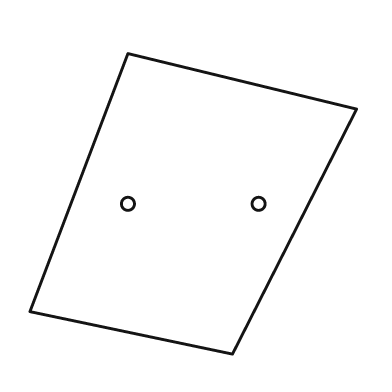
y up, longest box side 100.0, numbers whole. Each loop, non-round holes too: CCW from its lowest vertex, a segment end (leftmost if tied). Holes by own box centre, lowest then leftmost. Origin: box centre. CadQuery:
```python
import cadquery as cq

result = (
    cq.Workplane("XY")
    .moveTo(12.0, -46.0)
    .lineTo(50.0, 29.0)
    .lineTo(-20.0, 46.0)
    .lineTo(-50.0, -33.0)
    .close()
    .moveTo(-20.0, 0.0)
    .circle(2.0)
    .moveTo(20.0, 0.0)
    .circle(2.0)
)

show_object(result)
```